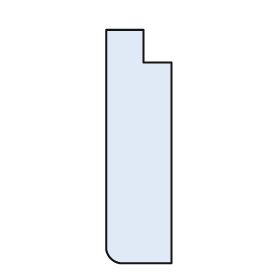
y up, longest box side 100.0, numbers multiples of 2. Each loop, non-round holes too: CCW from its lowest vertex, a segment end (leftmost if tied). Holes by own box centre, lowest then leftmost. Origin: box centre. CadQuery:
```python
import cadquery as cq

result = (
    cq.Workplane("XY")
    .moveTo(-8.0, -50.0)
    .lineTo(14.0, -50.0)
    .lineTo(14.0, 36.0)
    .lineTo(2.0, 36.0)
    .lineTo(2.0, 50.0)
    .lineTo(-14.0, 50.0)
    .lineTo(-14.0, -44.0)
    .threePointArc((-12.0, -48.0), (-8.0, -50.0))
    .close()
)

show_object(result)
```